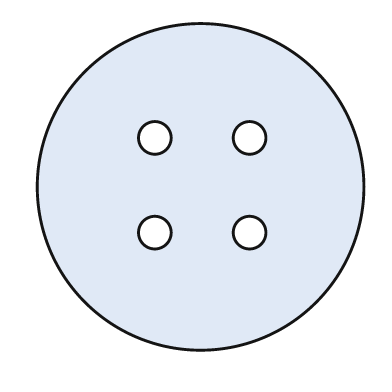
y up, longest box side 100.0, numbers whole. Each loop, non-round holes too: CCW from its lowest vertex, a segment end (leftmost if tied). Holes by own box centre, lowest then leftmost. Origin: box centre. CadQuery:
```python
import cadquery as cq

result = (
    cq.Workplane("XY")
    .moveTo(0.0, 0.0)
    .circle(50.0)
    .moveTo(-14.0, -14.0)
    .circle(5.0)
    .moveTo(15.0, -14.0)
    .circle(5.0)
    .moveTo(-14.0, 15.0)
    .circle(5.0)
    .moveTo(15.0, 15.0)
    .circle(5.0)
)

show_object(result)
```